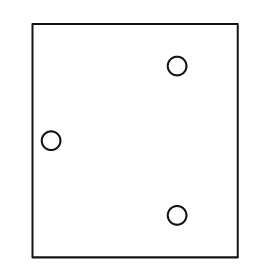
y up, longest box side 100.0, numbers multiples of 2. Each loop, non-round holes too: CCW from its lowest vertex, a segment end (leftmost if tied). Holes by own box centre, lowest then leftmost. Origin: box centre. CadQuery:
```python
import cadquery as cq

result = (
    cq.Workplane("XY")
    .moveTo(-44.0, -50.0)
    .lineTo(44.0, -50.0)
    .lineTo(44.0, 50.0)
    .lineTo(-44.0, 50.0)
    .close()
    .moveTo(18.0, -32.0)
    .circle(4.0)
    .moveTo(-36.0, 0.0)
    .circle(4.0)
    .moveTo(18.0, 32.0)
    .circle(4.0)
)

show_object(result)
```